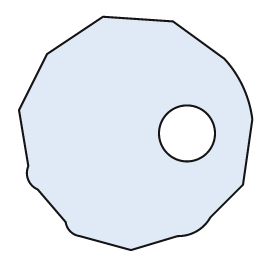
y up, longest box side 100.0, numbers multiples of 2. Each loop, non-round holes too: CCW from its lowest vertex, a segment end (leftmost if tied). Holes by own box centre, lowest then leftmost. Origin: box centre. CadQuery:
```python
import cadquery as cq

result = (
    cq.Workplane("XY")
    .moveTo(-2.0, -50.0)
    .lineTo(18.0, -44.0)
    .threePointArc((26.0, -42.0), (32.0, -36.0))
    .lineTo(46.0, -22.0)
    .lineTo(50.0, 6.0)
    .threePointArc((46.0, 20.0), (38.0, 32.0))
    .lineTo(16.0, 48.0)
    .lineTo(-14.0, 50.0)
    .lineTo(-38.0, 34.0)
    .lineTo(-50.0, 10.0)
    .lineTo(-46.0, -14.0)
    .threePointArc((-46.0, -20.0), (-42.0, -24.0))
    .lineTo(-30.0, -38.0)
    .threePointArc((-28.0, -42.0), (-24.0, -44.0))
    .close()
    .moveTo(22.0, 0.0)
    .circle(12.0)
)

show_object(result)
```